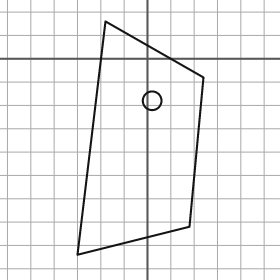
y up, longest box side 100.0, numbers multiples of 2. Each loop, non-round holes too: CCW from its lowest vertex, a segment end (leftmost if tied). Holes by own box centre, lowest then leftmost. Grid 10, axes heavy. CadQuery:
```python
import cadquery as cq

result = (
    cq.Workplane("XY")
    .moveTo(-30.0, -84.0)
    .lineTo(18.0, -72.0)
    .lineTo(24.0, -8.0)
    .lineTo(-18.0, 16.0)
    .close()
    .moveTo(2.0, -18.0)
    .circle(4.0)
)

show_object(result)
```